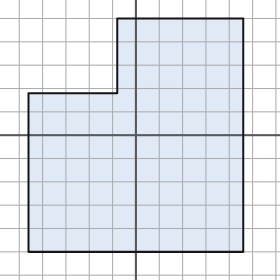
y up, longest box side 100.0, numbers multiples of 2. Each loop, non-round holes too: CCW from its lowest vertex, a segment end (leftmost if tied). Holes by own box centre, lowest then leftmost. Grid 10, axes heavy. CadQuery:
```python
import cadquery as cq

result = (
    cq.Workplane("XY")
    .moveTo(-46.0, -50.0)
    .lineTo(46.0, -50.0)
    .lineTo(46.0, 50.0)
    .lineTo(-8.0, 50.0)
    .lineTo(-8.0, 18.0)
    .lineTo(-46.0, 18.0)
    .close()
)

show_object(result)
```